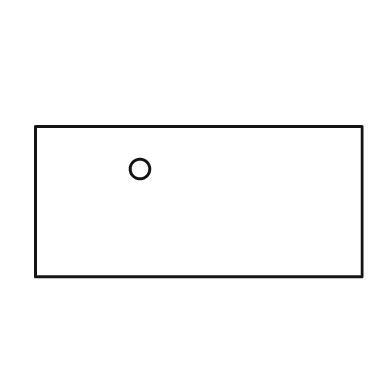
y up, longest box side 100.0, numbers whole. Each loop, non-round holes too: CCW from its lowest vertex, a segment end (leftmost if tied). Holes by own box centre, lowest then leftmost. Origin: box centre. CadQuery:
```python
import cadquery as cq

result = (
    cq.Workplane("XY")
    .moveTo(-50.0, -23.0)
    .lineTo(50.0, -23.0)
    .lineTo(50.0, 23.0)
    .lineTo(-50.0, 23.0)
    .close()
    .moveTo(-18.0, 10.0)
    .circle(3.0)
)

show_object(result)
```